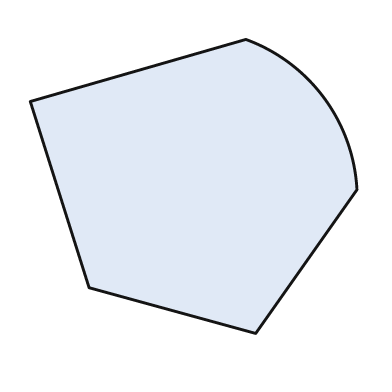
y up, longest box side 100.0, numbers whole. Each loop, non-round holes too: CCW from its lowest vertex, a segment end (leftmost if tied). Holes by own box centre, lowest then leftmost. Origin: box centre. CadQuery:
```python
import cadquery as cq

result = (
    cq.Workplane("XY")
    .moveTo(19.0, -45.0)
    .lineTo(50.0, -1.0)
    .threePointArc((40.0, 27.0), (16.0, 45.0))
    .lineTo(-50.0, 26.0)
    .lineTo(-32.0, -31.0)
    .close()
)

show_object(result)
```